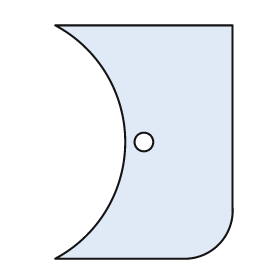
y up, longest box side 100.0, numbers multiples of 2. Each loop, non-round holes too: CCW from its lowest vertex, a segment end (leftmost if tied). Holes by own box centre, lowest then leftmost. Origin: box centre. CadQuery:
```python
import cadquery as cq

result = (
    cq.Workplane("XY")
    .moveTo(-38.0, -50.0)
    .lineTo(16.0, -50.0)
    .threePointArc((32.0, -44.0), (38.0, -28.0))
    .lineTo(38.0, 50.0)
    .lineTo(-38.0, 50.0)
    .threePointArc((-8.0, 0.0), (-38.0, -50.0))
    .close()
    .moveTo(0.0, 0.0)
    .circle(4.0)
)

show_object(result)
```